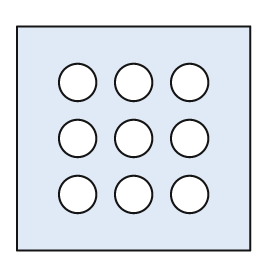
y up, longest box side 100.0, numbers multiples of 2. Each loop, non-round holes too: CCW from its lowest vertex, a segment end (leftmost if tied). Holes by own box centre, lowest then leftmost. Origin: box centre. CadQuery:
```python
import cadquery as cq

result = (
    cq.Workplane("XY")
    .moveTo(-50.0, -48.0)
    .lineTo(50.0, -48.0)
    .lineTo(50.0, 48.0)
    .lineTo(-50.0, 48.0)
    .close()
    .moveTo(-24.0, -24.0)
    .circle(8.0)
    .moveTo(0.0, -24.0)
    .circle(8.0)
    .moveTo(24.0, -24.0)
    .circle(8.0)
    .moveTo(-24.0, 0.0)
    .circle(8.0)
    .moveTo(0.0, 0.0)
    .circle(8.0)
    .moveTo(24.0, 0.0)
    .circle(8.0)
    .moveTo(-24.0, 24.0)
    .circle(8.0)
    .moveTo(0.0, 24.0)
    .circle(8.0)
    .moveTo(24.0, 24.0)
    .circle(8.0)
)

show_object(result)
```